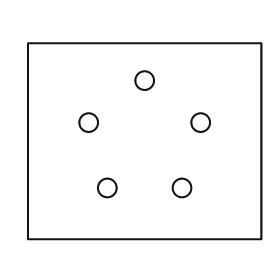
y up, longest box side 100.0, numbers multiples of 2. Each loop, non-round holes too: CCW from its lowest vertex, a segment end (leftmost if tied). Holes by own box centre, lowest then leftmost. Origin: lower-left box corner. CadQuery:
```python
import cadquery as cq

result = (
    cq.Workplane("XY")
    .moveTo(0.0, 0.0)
    .lineTo(100.0, 0.0)
    .lineTo(100.0, 84.0)
    .lineTo(0.0, 84.0)
    .close()
    .moveTo(34.0, 22.0)
    .circle(4.0)
    .moveTo(66.0, 22.0)
    .circle(4.0)
    .moveTo(26.0, 50.0)
    .circle(4.0)
    .moveTo(74.0, 50.0)
    .circle(4.0)
    .moveTo(50.0, 68.0)
    .circle(4.0)
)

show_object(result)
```